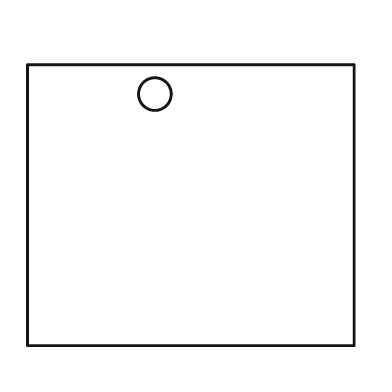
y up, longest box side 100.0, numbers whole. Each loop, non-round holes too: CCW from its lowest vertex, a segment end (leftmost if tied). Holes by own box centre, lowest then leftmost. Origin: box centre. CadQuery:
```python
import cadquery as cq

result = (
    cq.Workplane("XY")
    .moveTo(-50.0, -43.0)
    .lineTo(50.0, -43.0)
    .lineTo(50.0, 43.0)
    .lineTo(-50.0, 43.0)
    .close()
    .moveTo(-11.0, 34.0)
    .circle(5.0)
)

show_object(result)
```